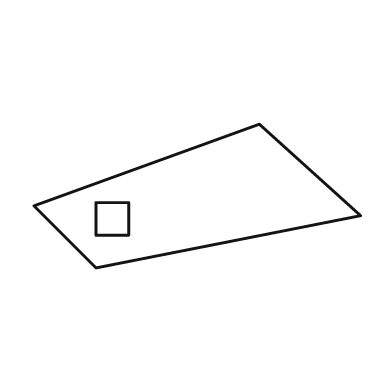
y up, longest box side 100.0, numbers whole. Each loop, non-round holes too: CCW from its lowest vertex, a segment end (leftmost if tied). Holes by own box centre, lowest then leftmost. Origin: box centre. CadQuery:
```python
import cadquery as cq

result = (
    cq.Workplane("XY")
    .moveTo(-31.0, -22.0)
    .lineTo(50.0, -6.0)
    .lineTo(19.0, 22.0)
    .lineTo(-50.0, -3.0)
    .close()
    .moveTo(-31.0, -12.0)
    .lineTo(-21.0, -12.0)
    .lineTo(-21.0, -2.0)
    .lineTo(-31.0, -2.0)
    .close()
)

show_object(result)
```